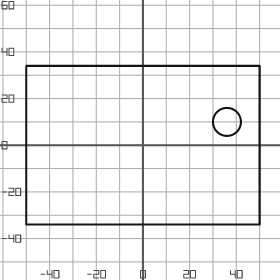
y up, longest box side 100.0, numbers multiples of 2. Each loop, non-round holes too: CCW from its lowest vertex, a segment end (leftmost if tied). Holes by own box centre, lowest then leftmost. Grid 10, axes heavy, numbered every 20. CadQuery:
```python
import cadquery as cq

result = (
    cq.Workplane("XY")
    .moveTo(-50.0, -34.0)
    .lineTo(50.0, -34.0)
    .lineTo(50.0, 34.0)
    .lineTo(-50.0, 34.0)
    .close()
    .moveTo(36.0, 10.0)
    .circle(6.0)
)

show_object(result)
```